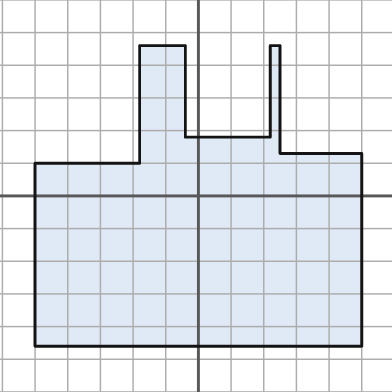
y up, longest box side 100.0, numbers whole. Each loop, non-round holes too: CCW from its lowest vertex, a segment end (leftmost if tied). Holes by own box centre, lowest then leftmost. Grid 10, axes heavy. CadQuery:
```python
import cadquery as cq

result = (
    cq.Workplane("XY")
    .moveTo(-50.0, -46.0)
    .lineTo(50.0, -46.0)
    .lineTo(50.0, 13.0)
    .lineTo(25.0, 13.0)
    .lineTo(25.0, 46.0)
    .lineTo(22.0, 46.0)
    .lineTo(22.0, 18.0)
    .lineTo(-4.0, 18.0)
    .lineTo(-4.0, 46.0)
    .lineTo(-18.0, 46.0)
    .lineTo(-18.0, 10.0)
    .lineTo(-50.0, 10.0)
    .close()
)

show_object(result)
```